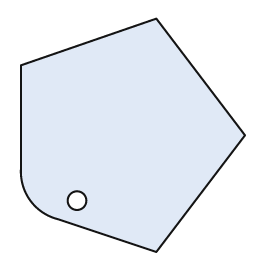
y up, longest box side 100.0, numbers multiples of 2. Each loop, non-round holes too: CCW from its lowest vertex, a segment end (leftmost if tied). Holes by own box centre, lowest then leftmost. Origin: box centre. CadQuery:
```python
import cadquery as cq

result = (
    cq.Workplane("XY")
    .moveTo(10.0, -50.0)
    .lineTo(48.0, 0.0)
    .lineTo(10.0, 50.0)
    .lineTo(-48.0, 30.0)
    .lineTo(-48.0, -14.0)
    .threePointArc((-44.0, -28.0), (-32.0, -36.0))
    .close()
    .moveTo(-24.0, -28.0)
    .circle(4.0)
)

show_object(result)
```